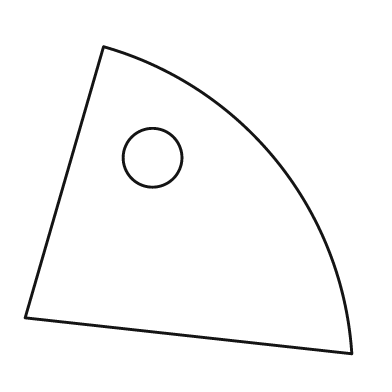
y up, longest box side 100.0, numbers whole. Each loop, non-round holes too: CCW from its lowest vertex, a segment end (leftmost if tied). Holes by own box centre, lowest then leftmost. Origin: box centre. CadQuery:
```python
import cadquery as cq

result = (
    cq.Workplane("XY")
    .moveTo(50.0, -47.0)
    .threePointArc((27.0, 12.0), (-26.0, 47.0))
    .lineTo(-50.0, -36.0)
    .close()
    .moveTo(-11.0, 13.0)
    .circle(9.0)
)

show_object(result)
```